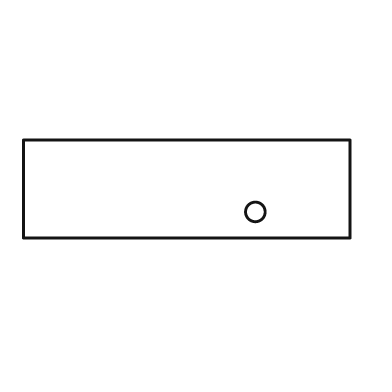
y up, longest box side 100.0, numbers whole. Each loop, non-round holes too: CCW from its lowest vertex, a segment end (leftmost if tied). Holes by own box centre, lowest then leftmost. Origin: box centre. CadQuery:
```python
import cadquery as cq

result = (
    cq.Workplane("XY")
    .moveTo(-50.0, -15.0)
    .lineTo(50.0, -15.0)
    .lineTo(50.0, 15.0)
    .lineTo(-50.0, 15.0)
    .close()
    .moveTo(21.0, -7.0)
    .circle(3.0)
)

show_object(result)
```